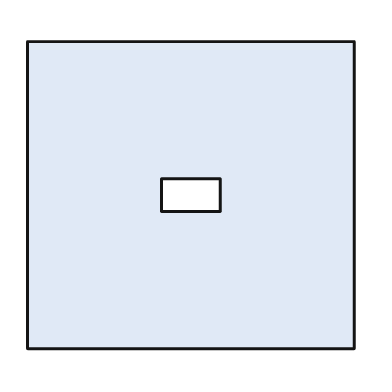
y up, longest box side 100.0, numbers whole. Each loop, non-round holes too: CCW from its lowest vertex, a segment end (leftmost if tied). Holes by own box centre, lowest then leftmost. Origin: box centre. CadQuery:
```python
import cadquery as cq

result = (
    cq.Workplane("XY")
    .moveTo(-50.0, -47.0)
    .lineTo(50.0, -47.0)
    .lineTo(50.0, 47.0)
    .lineTo(-50.0, 47.0)
    .close()
    .moveTo(-9.0, -5.0)
    .lineTo(9.0, -5.0)
    .lineTo(9.0, 5.0)
    .lineTo(-9.0, 5.0)
    .close()
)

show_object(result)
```